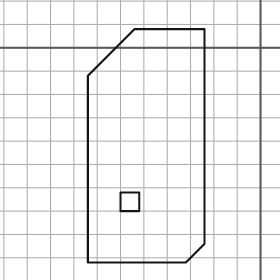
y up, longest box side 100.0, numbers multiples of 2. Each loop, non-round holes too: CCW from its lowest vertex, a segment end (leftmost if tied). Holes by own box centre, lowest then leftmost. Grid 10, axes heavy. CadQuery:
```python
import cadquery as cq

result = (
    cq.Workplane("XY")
    .moveTo(-74.0, -92.0)
    .lineTo(-32.0, -92.0)
    .lineTo(-24.0, -84.0)
    .lineTo(-24.0, 8.0)
    .lineTo(-54.0, 8.0)
    .lineTo(-74.0, -12.0)
    .close()
    .moveTo(-60.0, -70.0)
    .lineTo(-52.0, -70.0)
    .lineTo(-52.0, -62.0)
    .lineTo(-60.0, -62.0)
    .close()
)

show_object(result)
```